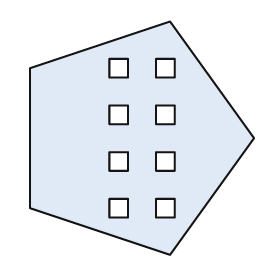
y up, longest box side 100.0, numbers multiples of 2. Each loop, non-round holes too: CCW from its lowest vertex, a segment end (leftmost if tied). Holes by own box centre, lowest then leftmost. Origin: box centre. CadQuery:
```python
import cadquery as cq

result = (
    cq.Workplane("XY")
    .moveTo(12.0, -50.0)
    .lineTo(48.0, 0.0)
    .lineTo(12.0, 50.0)
    .lineTo(-48.0, 30.0)
    .lineTo(-48.0, -30.0)
    .close()
    .moveTo(-14.0, -34.0)
    .lineTo(-6.0, -34.0)
    .lineTo(-6.0, -26.0)
    .lineTo(-14.0, -26.0)
    .close()
    .moveTo(6.0, -34.0)
    .lineTo(14.0, -34.0)
    .lineTo(14.0, -26.0)
    .lineTo(6.0, -26.0)
    .close()
    .moveTo(-14.0, -14.0)
    .lineTo(-6.0, -14.0)
    .lineTo(-6.0, -6.0)
    .lineTo(-14.0, -6.0)
    .close()
    .moveTo(6.0, -14.0)
    .lineTo(14.0, -14.0)
    .lineTo(14.0, -6.0)
    .lineTo(6.0, -6.0)
    .close()
    .moveTo(-14.0, 6.0)
    .lineTo(-6.0, 6.0)
    .lineTo(-6.0, 14.0)
    .lineTo(-14.0, 14.0)
    .close()
    .moveTo(6.0, 6.0)
    .lineTo(14.0, 6.0)
    .lineTo(14.0, 14.0)
    .lineTo(6.0, 14.0)
    .close()
    .moveTo(-14.0, 26.0)
    .lineTo(-6.0, 26.0)
    .lineTo(-6.0, 34.0)
    .lineTo(-14.0, 34.0)
    .close()
    .moveTo(6.0, 26.0)
    .lineTo(14.0, 26.0)
    .lineTo(14.0, 34.0)
    .lineTo(6.0, 34.0)
    .close()
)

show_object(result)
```